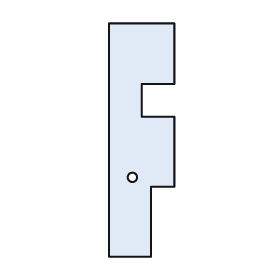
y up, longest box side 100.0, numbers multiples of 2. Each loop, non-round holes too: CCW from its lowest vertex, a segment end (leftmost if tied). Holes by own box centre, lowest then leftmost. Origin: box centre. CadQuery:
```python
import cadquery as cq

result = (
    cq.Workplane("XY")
    .moveTo(-14.0, -50.0)
    .lineTo(4.0, -50.0)
    .lineTo(4.0, -20.0)
    .lineTo(14.0, -20.0)
    .lineTo(14.0, 10.0)
    .lineTo(0.0, 10.0)
    .lineTo(0.0, 24.0)
    .lineTo(14.0, 24.0)
    .lineTo(14.0, 50.0)
    .lineTo(-14.0, 50.0)
    .close()
    .moveTo(-4.0, -16.0)
    .circle(2.0)
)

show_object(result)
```